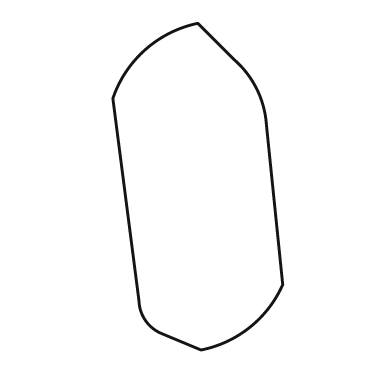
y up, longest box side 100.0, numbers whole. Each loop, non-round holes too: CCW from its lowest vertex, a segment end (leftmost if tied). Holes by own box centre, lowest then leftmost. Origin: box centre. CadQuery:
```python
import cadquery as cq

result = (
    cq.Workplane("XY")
    .moveTo(1.0, -50.0)
    .threePointArc((16.0, -43.0), (26.0, -30.0))
    .lineTo(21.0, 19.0)
    .threePointArc((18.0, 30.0), (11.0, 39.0))
    .lineTo(0.0, 50.0)
    .threePointArc((-16.0, 42.0), (-26.0, 27.0))
    .lineTo(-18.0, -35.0)
    .threePointArc((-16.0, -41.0), (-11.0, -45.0))
    .close()
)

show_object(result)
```